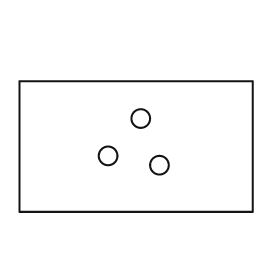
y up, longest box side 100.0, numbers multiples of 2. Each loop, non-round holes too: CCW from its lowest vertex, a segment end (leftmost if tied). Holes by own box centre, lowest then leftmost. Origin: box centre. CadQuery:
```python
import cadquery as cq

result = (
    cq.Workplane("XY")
    .moveTo(-50.0, -28.0)
    .lineTo(50.0, -28.0)
    .lineTo(50.0, 28.0)
    .lineTo(-50.0, 28.0)
    .close()
    .moveTo(10.0, -8.0)
    .circle(4.0)
    .moveTo(-12.0, -4.0)
    .circle(4.0)
    .moveTo(2.0, 12.0)
    .circle(4.0)
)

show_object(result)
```